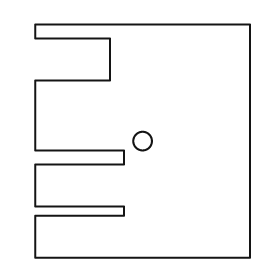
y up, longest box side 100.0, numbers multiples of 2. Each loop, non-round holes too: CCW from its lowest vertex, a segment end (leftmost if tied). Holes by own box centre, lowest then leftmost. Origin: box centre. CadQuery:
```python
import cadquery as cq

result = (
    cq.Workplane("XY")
    .moveTo(-46.0, -50.0)
    .lineTo(46.0, -50.0)
    .lineTo(46.0, 50.0)
    .lineTo(-46.0, 50.0)
    .lineTo(-46.0, 44.0)
    .lineTo(-14.0, 44.0)
    .lineTo(-14.0, 26.0)
    .lineTo(-46.0, 26.0)
    .lineTo(-46.0, -4.0)
    .lineTo(-8.0, -4.0)
    .lineTo(-8.0, -10.0)
    .lineTo(-46.0, -10.0)
    .lineTo(-46.0, -28.0)
    .lineTo(-8.0, -28.0)
    .lineTo(-8.0, -32.0)
    .lineTo(-46.0, -32.0)
    .close()
    .moveTo(0.0, 0.0)
    .circle(4.0)
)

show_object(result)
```